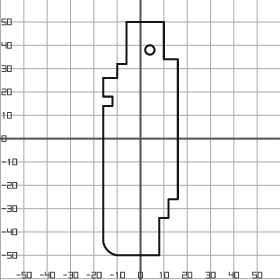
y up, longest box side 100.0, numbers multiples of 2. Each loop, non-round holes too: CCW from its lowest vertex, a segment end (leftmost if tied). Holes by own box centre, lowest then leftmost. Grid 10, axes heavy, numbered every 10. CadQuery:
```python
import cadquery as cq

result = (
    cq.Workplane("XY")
    .moveTo(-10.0, -50.0)
    .lineTo(8.0, -50.0)
    .lineTo(8.0, -34.0)
    .lineTo(12.0, -34.0)
    .lineTo(12.0, -26.0)
    .lineTo(16.0, -26.0)
    .lineTo(16.0, 34.0)
    .lineTo(10.0, 34.0)
    .lineTo(10.0, 50.0)
    .lineTo(-6.0, 50.0)
    .lineTo(-6.0, 32.0)
    .lineTo(-10.0, 32.0)
    .lineTo(-10.0, 26.0)
    .lineTo(-16.0, 26.0)
    .lineTo(-16.0, 18.0)
    .lineTo(-12.0, 18.0)
    .lineTo(-12.0, 14.0)
    .lineTo(-16.0, 14.0)
    .lineTo(-16.0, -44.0)
    .threePointArc((-14.0, -48.0), (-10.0, -50.0))
    .close()
    .moveTo(4.0, 38.0)
    .circle(2.0)
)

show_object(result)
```